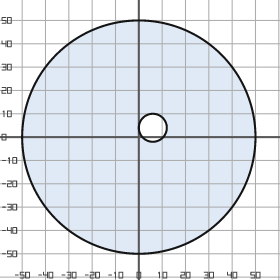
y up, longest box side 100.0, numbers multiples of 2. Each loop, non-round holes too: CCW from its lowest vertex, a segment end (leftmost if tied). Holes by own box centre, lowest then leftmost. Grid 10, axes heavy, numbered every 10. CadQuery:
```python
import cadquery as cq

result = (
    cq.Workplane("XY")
    .moveTo(0.0, 0.0)
    .circle(50.0)
    .moveTo(6.0, 4.0)
    .circle(6.0)
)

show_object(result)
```